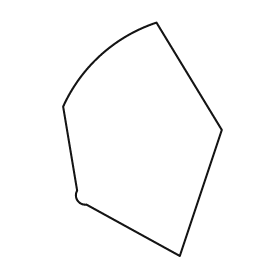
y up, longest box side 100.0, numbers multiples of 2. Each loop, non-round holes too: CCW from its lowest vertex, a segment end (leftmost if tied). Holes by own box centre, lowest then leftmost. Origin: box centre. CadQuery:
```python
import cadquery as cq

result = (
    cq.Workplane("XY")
    .moveTo(16.0, -50.0)
    .lineTo(34.0, 4.0)
    .lineTo(6.0, 50.0)
    .threePointArc((-18.0, 36.0), (-34.0, 14.0))
    .lineTo(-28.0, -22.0)
    .threePointArc((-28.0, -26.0), (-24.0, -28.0))
    .close()
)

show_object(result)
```